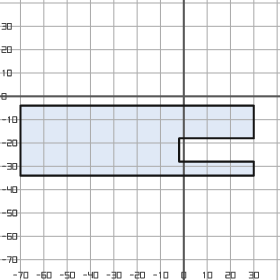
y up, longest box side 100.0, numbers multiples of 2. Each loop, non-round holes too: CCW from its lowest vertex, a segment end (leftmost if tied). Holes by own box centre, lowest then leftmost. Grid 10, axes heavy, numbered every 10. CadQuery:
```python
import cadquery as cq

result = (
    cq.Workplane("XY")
    .moveTo(-70.0, -34.0)
    .lineTo(30.0, -34.0)
    .lineTo(30.0, -28.0)
    .lineTo(-2.0, -28.0)
    .lineTo(-2.0, -18.0)
    .lineTo(30.0, -18.0)
    .lineTo(30.0, -4.0)
    .lineTo(-70.0, -4.0)
    .close()
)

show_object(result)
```